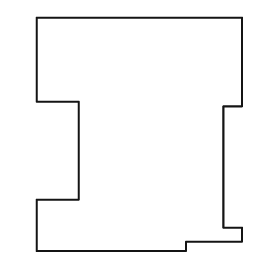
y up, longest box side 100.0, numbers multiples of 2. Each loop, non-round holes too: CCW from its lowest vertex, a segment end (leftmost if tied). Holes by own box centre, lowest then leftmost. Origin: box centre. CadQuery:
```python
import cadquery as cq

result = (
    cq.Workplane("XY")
    .moveTo(-44.0, -50.0)
    .lineTo(20.0, -50.0)
    .lineTo(20.0, -46.0)
    .lineTo(44.0, -46.0)
    .lineTo(44.0, -40.0)
    .lineTo(36.0, -40.0)
    .lineTo(36.0, 12.0)
    .lineTo(44.0, 12.0)
    .lineTo(44.0, 50.0)
    .lineTo(-44.0, 50.0)
    .lineTo(-44.0, 14.0)
    .lineTo(-26.0, 14.0)
    .lineTo(-26.0, -28.0)
    .lineTo(-44.0, -28.0)
    .close()
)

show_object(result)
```